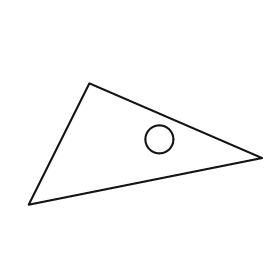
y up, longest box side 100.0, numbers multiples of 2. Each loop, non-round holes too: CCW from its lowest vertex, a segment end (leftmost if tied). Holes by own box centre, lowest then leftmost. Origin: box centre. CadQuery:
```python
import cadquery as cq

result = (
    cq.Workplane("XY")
    .moveTo(-50.0, -26.0)
    .lineTo(50.0, -6.0)
    .lineTo(-24.0, 26.0)
    .close()
    .moveTo(6.0, 2.0)
    .circle(6.0)
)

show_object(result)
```